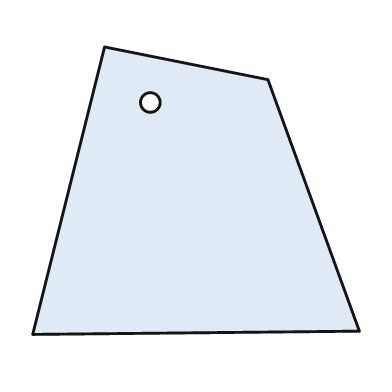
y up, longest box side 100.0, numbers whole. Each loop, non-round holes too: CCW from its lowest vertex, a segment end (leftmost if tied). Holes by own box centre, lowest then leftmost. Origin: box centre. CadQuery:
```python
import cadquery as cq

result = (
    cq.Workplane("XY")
    .moveTo(-50.0, -44.0)
    .lineTo(50.0, -43.0)
    .lineTo(22.0, 34.0)
    .lineTo(-28.0, 44.0)
    .close()
    .moveTo(-14.0, 27.0)
    .circle(3.0)
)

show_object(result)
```